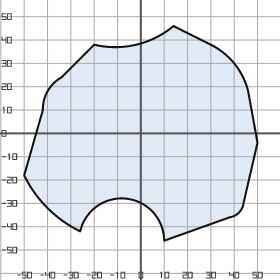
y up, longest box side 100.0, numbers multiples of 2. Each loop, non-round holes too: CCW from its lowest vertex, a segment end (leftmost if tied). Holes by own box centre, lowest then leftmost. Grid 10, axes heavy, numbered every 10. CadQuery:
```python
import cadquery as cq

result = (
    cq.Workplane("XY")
    .moveTo(10.0, -46.0)
    .lineTo(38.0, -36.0)
    .threePointArc((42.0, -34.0), (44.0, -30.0))
    .lineTo(50.0, -4.0)
    .lineTo(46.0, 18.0)
    .threePointArc((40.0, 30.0), (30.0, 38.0))
    .lineTo(14.0, 46.0)
    .threePointArc((-2.0, 38.0), (-20.0, 38.0))
    .lineTo(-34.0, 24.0)
    .threePointArc((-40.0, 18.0), (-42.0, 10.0))
    .lineTo(-50.0, -18.0)
    .threePointArc((-40.0, -32.0), (-26.0, -42.0))
    .threePointArc((-6.0, -28.0), (10.0, -46.0))
    .close()
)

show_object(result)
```